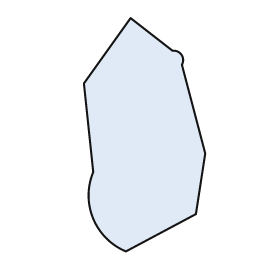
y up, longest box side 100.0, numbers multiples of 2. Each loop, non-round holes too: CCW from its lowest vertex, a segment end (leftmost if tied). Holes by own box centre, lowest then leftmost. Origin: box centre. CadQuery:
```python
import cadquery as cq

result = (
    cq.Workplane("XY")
    .moveTo(-8.0, -50.0)
    .lineTo(22.0, -34.0)
    .lineTo(26.0, -8.0)
    .lineTo(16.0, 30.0)
    .threePointArc((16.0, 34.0), (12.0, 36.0))
    .lineTo(-6.0, 50.0)
    .lineTo(-26.0, 22.0)
    .lineTo(-22.0, -16.0)
    .threePointArc((-22.0, -36.0), (-8.0, -50.0))
    .close()
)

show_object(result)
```